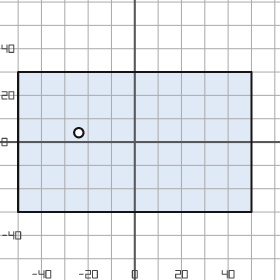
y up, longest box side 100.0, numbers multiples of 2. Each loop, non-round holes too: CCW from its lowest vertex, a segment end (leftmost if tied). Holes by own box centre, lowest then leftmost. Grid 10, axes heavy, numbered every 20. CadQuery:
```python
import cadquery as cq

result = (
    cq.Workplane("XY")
    .moveTo(-50.0, -30.0)
    .lineTo(50.0, -30.0)
    .lineTo(50.0, 30.0)
    .lineTo(-50.0, 30.0)
    .close()
    .moveTo(-24.0, 4.0)
    .circle(2.0)
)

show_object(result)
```